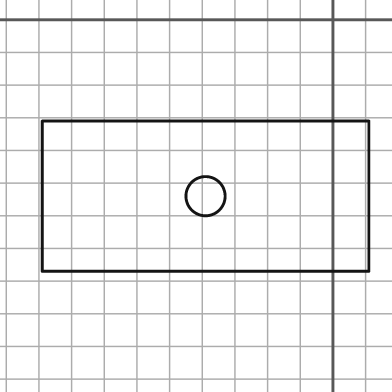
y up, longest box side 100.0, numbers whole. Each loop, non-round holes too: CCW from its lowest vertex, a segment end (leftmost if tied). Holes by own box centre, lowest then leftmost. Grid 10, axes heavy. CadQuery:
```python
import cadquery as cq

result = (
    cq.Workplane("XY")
    .moveTo(-89.0, -77.0)
    .lineTo(11.0, -77.0)
    .lineTo(11.0, -31.0)
    .lineTo(-89.0, -31.0)
    .close()
    .moveTo(-39.0, -54.0)
    .circle(6.0)
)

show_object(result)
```